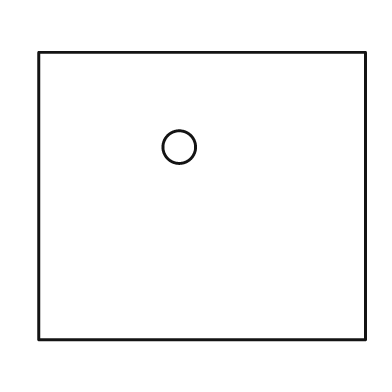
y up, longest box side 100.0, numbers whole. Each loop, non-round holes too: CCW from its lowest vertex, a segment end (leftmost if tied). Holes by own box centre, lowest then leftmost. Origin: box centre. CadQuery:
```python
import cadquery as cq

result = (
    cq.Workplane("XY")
    .moveTo(-50.0, -44.0)
    .lineTo(50.0, -44.0)
    .lineTo(50.0, 44.0)
    .lineTo(-50.0, 44.0)
    .close()
    .moveTo(-7.0, 15.0)
    .circle(5.0)
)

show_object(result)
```